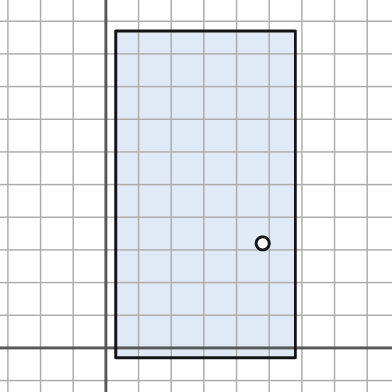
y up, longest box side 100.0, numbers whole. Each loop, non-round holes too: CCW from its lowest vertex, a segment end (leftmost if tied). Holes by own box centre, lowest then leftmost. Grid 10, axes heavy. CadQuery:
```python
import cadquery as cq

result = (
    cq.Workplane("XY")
    .moveTo(3.0, -3.0)
    .lineTo(58.0, -3.0)
    .lineTo(58.0, 97.0)
    .lineTo(3.0, 97.0)
    .close()
    .moveTo(48.0, 32.0)
    .circle(2.0)
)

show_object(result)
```